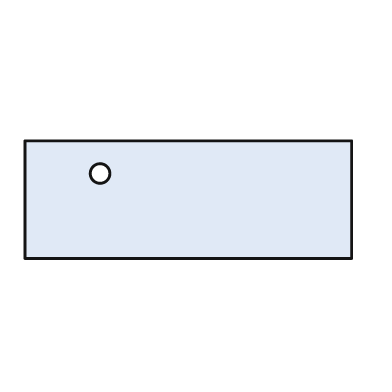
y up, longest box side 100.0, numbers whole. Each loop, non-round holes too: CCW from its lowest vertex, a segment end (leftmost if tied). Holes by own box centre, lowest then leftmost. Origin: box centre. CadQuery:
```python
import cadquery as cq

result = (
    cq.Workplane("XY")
    .moveTo(-50.0, -18.0)
    .lineTo(50.0, -18.0)
    .lineTo(50.0, 18.0)
    .lineTo(-50.0, 18.0)
    .close()
    .moveTo(-27.0, 8.0)
    .circle(3.0)
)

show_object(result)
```